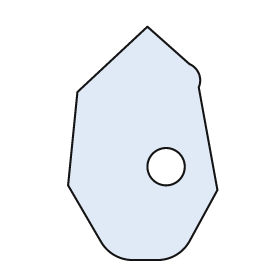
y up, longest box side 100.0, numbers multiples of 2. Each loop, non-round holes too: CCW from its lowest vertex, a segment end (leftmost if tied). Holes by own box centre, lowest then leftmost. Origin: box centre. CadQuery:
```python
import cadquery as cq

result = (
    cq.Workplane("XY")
    .moveTo(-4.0, -50.0)
    .lineTo(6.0, -50.0)
    .threePointArc((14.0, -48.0), (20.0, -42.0))
    .lineTo(32.0, -20.0)
    .lineTo(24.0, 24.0)
    .threePointArc((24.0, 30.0), (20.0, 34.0))
    .lineTo(2.0, 50.0)
    .lineTo(-28.0, 22.0)
    .lineTo(-32.0, -18.0)
    .lineTo(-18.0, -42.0)
    .threePointArc((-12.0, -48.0), (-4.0, -50.0))
    .close()
    .moveTo(10.0, -10.0)
    .circle(8.0)
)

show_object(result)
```